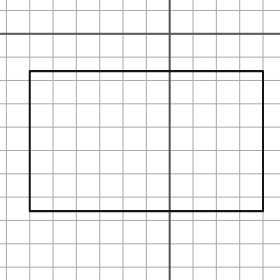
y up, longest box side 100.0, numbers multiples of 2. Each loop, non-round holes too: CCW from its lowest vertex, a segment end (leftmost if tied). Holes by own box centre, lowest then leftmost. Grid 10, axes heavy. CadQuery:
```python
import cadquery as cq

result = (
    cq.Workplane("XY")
    .moveTo(-60.0, -76.0)
    .lineTo(40.0, -76.0)
    .lineTo(40.0, -16.0)
    .lineTo(-60.0, -16.0)
    .close()
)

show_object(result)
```